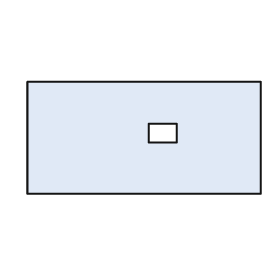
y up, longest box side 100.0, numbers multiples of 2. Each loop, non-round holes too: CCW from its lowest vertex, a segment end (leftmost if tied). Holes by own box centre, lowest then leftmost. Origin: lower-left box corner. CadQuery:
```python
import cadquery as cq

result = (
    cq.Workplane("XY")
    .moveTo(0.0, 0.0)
    .lineTo(100.0, 0.0)
    .lineTo(100.0, 48.0)
    .lineTo(0.0, 48.0)
    .close()
    .moveTo(52.0, 22.0)
    .lineTo(64.0, 22.0)
    .lineTo(64.0, 30.0)
    .lineTo(52.0, 30.0)
    .close()
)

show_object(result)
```